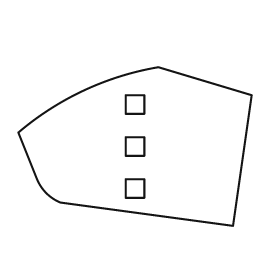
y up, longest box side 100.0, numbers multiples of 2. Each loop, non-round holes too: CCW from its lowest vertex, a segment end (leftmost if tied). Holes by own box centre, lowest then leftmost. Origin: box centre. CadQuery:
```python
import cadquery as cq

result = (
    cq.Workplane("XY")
    .moveTo(42.0, -34.0)
    .lineTo(50.0, 22.0)
    .lineTo(10.0, 34.0)
    .threePointArc((-22.0, 24.0), (-50.0, 6.0))
    .lineTo(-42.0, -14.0)
    .threePointArc((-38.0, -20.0), (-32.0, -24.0))
    .close()
    .moveTo(-4.0, -22.0)
    .lineTo(4.0, -22.0)
    .lineTo(4.0, -14.0)
    .lineTo(-4.0, -14.0)
    .close()
    .moveTo(-4.0, -4.0)
    .lineTo(4.0, -4.0)
    .lineTo(4.0, 4.0)
    .lineTo(-4.0, 4.0)
    .close()
    .moveTo(-4.0, 14.0)
    .lineTo(4.0, 14.0)
    .lineTo(4.0, 22.0)
    .lineTo(-4.0, 22.0)
    .close()
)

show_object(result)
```